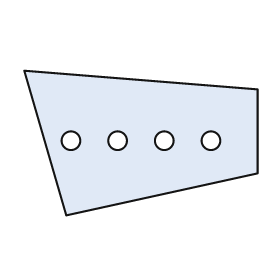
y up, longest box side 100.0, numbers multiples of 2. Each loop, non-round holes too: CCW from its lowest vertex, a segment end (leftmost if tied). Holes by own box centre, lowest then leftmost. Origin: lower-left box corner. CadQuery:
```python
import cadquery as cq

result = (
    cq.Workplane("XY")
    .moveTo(18.0, 0.0)
    .lineTo(100.0, 18.0)
    .lineTo(100.0, 54.0)
    .lineTo(0.0, 62.0)
    .close()
    .moveTo(20.0, 32.0)
    .circle(4.0)
    .moveTo(40.0, 32.0)
    .circle(4.0)
    .moveTo(60.0, 32.0)
    .circle(4.0)
    .moveTo(80.0, 32.0)
    .circle(4.0)
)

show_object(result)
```